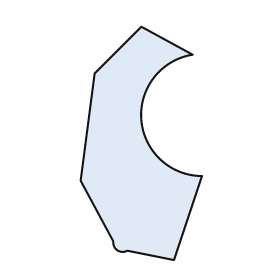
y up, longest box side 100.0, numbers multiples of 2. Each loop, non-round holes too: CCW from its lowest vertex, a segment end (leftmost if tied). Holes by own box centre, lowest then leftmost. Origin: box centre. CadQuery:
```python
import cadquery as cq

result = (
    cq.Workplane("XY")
    .moveTo(14.0, -50.0)
    .lineTo(26.0, -14.0)
    .threePointArc((0.0, 10.0), (22.0, 38.0))
    .lineTo(0.0, 50.0)
    .lineTo(-20.0, 30.0)
    .lineTo(-26.0, -16.0)
    .lineTo(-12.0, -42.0)
    .threePointArc((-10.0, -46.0), (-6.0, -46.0))
    .close()
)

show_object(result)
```